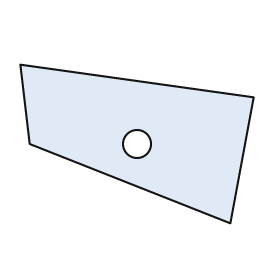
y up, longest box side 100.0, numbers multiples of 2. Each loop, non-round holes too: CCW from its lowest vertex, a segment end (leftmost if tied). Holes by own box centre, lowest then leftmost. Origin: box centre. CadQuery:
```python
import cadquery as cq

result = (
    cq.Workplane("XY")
    .moveTo(40.0, -34.0)
    .lineTo(50.0, 20.0)
    .lineTo(-50.0, 34.0)
    .lineTo(-46.0, 0.0)
    .close()
    .moveTo(0.0, 0.0)
    .circle(6.0)
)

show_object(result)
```